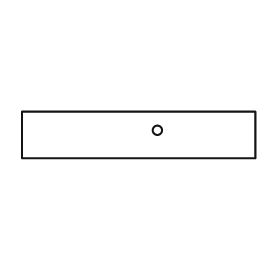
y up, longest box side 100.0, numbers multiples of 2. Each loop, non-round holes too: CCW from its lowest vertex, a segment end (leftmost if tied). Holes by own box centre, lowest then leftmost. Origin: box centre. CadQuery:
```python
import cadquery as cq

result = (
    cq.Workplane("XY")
    .moveTo(-50.0, -10.0)
    .lineTo(50.0, -10.0)
    .lineTo(50.0, 10.0)
    .lineTo(-50.0, 10.0)
    .close()
    .moveTo(8.0, 2.0)
    .circle(2.0)
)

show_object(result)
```